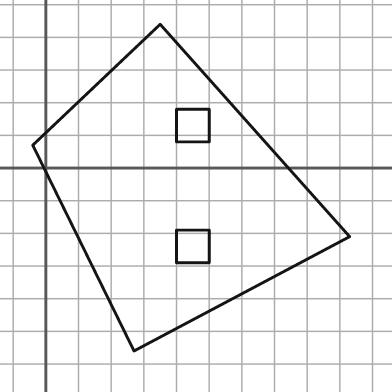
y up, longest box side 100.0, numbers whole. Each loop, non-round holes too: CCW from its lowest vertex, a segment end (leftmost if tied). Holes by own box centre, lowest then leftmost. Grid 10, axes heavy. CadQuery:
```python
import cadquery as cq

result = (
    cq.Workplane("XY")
    .moveTo(27.0, -56.0)
    .lineTo(93.0, -21.0)
    .lineTo(35.0, 44.0)
    .lineTo(-4.0, 7.0)
    .close()
    .moveTo(40.0, -29.0)
    .lineTo(50.0, -29.0)
    .lineTo(50.0, -19.0)
    .lineTo(40.0, -19.0)
    .close()
    .moveTo(40.0, 8.0)
    .lineTo(50.0, 8.0)
    .lineTo(50.0, 18.0)
    .lineTo(40.0, 18.0)
    .close()
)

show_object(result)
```